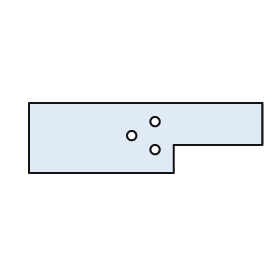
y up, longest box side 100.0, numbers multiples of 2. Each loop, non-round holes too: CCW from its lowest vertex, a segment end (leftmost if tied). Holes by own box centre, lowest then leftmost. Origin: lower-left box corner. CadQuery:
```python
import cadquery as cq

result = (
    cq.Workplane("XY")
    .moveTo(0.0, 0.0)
    .lineTo(62.0, 0.0)
    .lineTo(62.0, 12.0)
    .lineTo(100.0, 12.0)
    .lineTo(100.0, 30.0)
    .lineTo(0.0, 30.0)
    .close()
    .moveTo(54.0, 10.0)
    .circle(2.0)
    .moveTo(44.0, 16.0)
    .circle(2.0)
    .moveTo(54.0, 22.0)
    .circle(2.0)
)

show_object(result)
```